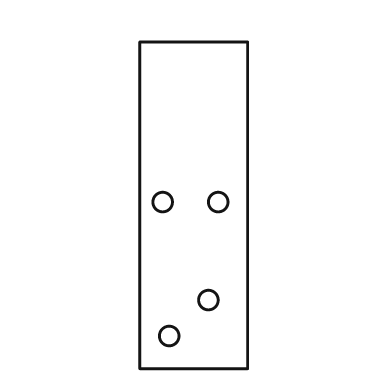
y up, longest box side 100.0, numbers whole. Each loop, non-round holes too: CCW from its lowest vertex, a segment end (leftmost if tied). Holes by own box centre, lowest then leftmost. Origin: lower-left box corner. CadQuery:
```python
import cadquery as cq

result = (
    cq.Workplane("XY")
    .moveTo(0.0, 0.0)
    .lineTo(33.0, 0.0)
    .lineTo(33.0, 100.0)
    .lineTo(0.0, 100.0)
    .close()
    .moveTo(9.0, 10.0)
    .circle(3.0)
    .moveTo(21.0, 21.0)
    .circle(3.0)
    .moveTo(7.0, 51.0)
    .circle(3.0)
    .moveTo(24.0, 51.0)
    .circle(3.0)
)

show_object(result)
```